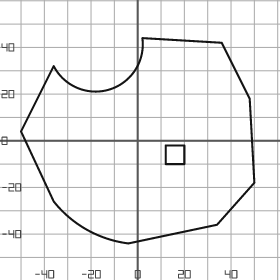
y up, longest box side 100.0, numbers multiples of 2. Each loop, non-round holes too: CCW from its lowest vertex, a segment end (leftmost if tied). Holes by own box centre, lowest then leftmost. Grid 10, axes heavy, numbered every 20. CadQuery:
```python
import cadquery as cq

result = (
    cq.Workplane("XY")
    .moveTo(-4.0, -44.0)
    .lineTo(34.0, -36.0)
    .lineTo(50.0, -18.0)
    .lineTo(48.0, 18.0)
    .lineTo(36.0, 42.0)
    .lineTo(2.0, 44.0)
    .threePointArc((-12.0, 22.0), (-36.0, 32.0))
    .lineTo(-50.0, 4.0)
    .lineTo(-36.0, -26.0)
    .threePointArc((-22.0, -38.0), (-4.0, -44.0))
    .close()
    .moveTo(12.0, -10.0)
    .lineTo(20.0, -10.0)
    .lineTo(20.0, -2.0)
    .lineTo(12.0, -2.0)
    .close()
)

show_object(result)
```